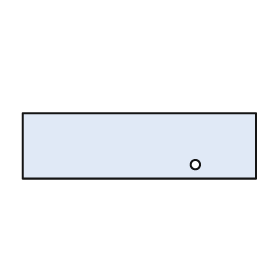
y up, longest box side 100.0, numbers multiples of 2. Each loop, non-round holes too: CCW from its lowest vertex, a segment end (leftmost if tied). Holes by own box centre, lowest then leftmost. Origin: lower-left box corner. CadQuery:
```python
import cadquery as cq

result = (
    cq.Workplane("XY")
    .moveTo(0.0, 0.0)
    .lineTo(100.0, 0.0)
    .lineTo(100.0, 28.0)
    .lineTo(0.0, 28.0)
    .close()
    .moveTo(74.0, 6.0)
    .circle(2.0)
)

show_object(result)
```